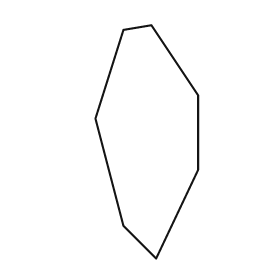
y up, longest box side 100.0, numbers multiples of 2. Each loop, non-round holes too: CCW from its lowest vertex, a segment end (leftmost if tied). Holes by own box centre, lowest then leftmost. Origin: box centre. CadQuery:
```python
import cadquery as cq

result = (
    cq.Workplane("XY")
    .moveTo(4.0, -50.0)
    .lineTo(22.0, -12.0)
    .lineTo(22.0, 20.0)
    .lineTo(2.0, 50.0)
    .lineTo(-10.0, 48.0)
    .lineTo(-22.0, 10.0)
    .lineTo(-10.0, -36.0)
    .close()
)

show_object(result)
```